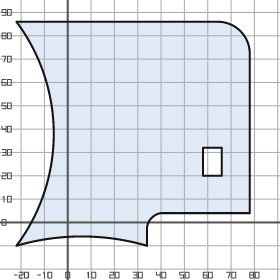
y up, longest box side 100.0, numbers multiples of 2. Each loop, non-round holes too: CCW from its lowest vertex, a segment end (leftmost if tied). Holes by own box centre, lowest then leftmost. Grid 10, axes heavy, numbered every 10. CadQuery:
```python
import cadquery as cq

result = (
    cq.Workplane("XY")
    .moveTo(-22.0, -10.0)
    .threePointArc((6.0, -6.0), (34.0, -10.0))
    .lineTo(34.0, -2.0)
    .threePointArc((36.0, 2.0), (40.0, 4.0))
    .lineTo(78.0, 4.0)
    .lineTo(78.0, 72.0)
    .threePointArc((74.0, 82.0), (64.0, 86.0))
    .lineTo(-22.0, 86.0)
    .threePointArc((-6.0, 38.0), (-22.0, -10.0))
    .close()
    .moveTo(58.0, 20.0)
    .lineTo(66.0, 20.0)
    .lineTo(66.0, 32.0)
    .lineTo(58.0, 32.0)
    .close()
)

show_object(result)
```